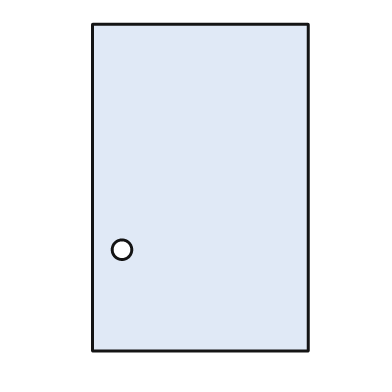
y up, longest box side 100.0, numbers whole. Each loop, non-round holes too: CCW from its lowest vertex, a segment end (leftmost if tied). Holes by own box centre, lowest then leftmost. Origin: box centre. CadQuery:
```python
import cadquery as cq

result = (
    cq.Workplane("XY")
    .moveTo(-33.0, -50.0)
    .lineTo(33.0, -50.0)
    .lineTo(33.0, 50.0)
    .lineTo(-33.0, 50.0)
    .close()
    .moveTo(-24.0, -19.0)
    .circle(3.0)
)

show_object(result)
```